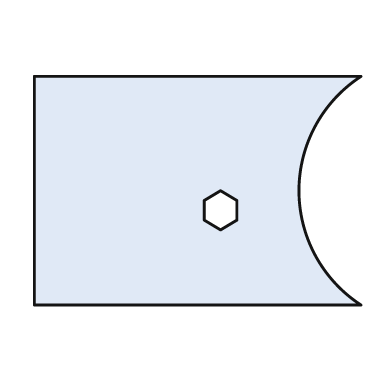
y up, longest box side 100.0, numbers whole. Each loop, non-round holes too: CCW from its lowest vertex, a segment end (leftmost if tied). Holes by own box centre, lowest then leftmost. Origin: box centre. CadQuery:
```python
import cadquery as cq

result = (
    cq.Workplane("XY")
    .moveTo(-50.0, -35.0)
    .lineTo(50.0, -35.0)
    .threePointArc((31.0, 0.0), (50.0, 35.0))
    .lineTo(-50.0, 35.0)
    .close()
    .moveTo(7.0, -12.0)
    .lineTo(12.0, -9.0)
    .lineTo(12.0, -3.0)
    .lineTo(7.0, 0.0)
    .lineTo(2.0, -3.0)
    .lineTo(2.0, -9.0)
    .close()
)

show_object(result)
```